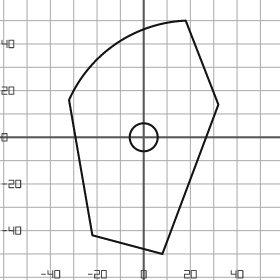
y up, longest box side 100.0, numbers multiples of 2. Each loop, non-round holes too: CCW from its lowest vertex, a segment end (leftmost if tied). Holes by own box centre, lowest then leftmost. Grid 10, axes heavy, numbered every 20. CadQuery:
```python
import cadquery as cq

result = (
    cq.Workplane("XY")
    .moveTo(8.0, -50.0)
    .lineTo(32.0, 14.0)
    .lineTo(18.0, 50.0)
    .threePointArc((-12.0, 40.0), (-32.0, 16.0))
    .lineTo(-22.0, -42.0)
    .close()
    .moveTo(0.0, 0.0)
    .circle(6.0)
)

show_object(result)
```